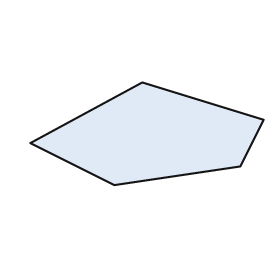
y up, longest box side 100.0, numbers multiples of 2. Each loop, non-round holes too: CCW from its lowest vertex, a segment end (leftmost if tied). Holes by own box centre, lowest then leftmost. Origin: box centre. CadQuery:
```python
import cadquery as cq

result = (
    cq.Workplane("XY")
    .moveTo(-14.0, -22.0)
    .lineTo(40.0, -14.0)
    .lineTo(50.0, 6.0)
    .lineTo(-2.0, 22.0)
    .lineTo(-50.0, -4.0)
    .close()
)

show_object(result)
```